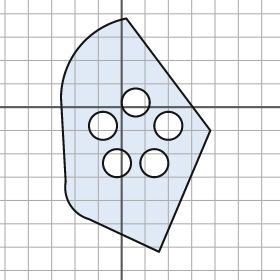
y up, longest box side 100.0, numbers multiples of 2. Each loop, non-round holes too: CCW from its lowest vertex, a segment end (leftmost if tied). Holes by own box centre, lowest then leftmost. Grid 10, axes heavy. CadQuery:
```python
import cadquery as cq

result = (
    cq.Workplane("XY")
    .moveTo(16.0, -62.0)
    .lineTo(38.0, -10.0)
    .lineTo(2.0, 38.0)
    .threePointArc((-18.0, 26.0), (-26.0, 4.0))
    .lineTo(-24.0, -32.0)
    .threePointArc((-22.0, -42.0), (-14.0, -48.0))
    .close()
    .moveTo(-2.0, -24.0)
    .circle(6.0)
    .moveTo(14.0, -24.0)
    .circle(6.0)
    .moveTo(-8.0, -8.0)
    .circle(6.0)
    .moveTo(20.0, -8.0)
    .circle(6.0)
    .moveTo(6.0, 2.0)
    .circle(6.0)
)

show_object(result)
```